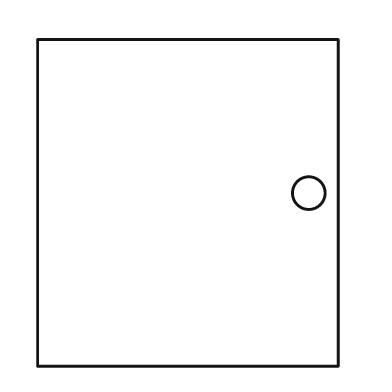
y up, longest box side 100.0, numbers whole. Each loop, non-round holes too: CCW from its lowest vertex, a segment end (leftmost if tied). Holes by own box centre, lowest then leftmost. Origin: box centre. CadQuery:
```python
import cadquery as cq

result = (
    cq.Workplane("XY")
    .moveTo(-46.0, -50.0)
    .lineTo(46.0, -50.0)
    .lineTo(46.0, 50.0)
    .lineTo(-46.0, 50.0)
    .close()
    .moveTo(37.0, 3.0)
    .circle(5.0)
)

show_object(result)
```